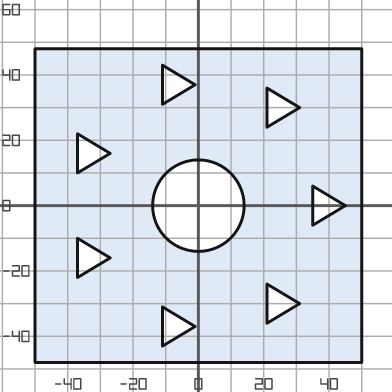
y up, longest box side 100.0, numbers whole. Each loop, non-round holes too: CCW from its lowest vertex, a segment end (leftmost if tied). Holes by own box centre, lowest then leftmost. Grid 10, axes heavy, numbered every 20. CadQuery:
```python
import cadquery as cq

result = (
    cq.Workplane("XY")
    .moveTo(-50.0, -48.0)
    .lineTo(50.0, -48.0)
    .lineTo(50.0, 48.0)
    .lineTo(-50.0, 48.0)
    .close()
    .moveTo(-11.0, -43.0)
    .lineTo(-1.0, -37.0)
    .lineTo(-11.0, -31.0)
    .close()
    .moveTo(21.0, -36.0)
    .lineTo(31.0, -30.0)
    .lineTo(21.0, -24.0)
    .close()
    .moveTo(-37.0, -22.0)
    .lineTo(-27.0, -16.0)
    .lineTo(-37.0, -10.0)
    .close()
    .moveTo(0.0, 0.0)
    .circle(14.0)
    .moveTo(35.0, -6.0)
    .lineTo(45.0, 0.0)
    .lineTo(35.0, 6.0)
    .close()
    .moveTo(-37.0, 10.0)
    .lineTo(-27.0, 16.0)
    .lineTo(-37.0, 22.0)
    .close()
    .moveTo(21.0, 24.0)
    .lineTo(31.0, 30.0)
    .lineTo(21.0, 36.0)
    .close()
    .moveTo(-11.0, 31.0)
    .lineTo(-1.0, 37.0)
    .lineTo(-11.0, 43.0)
    .close()
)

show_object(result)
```